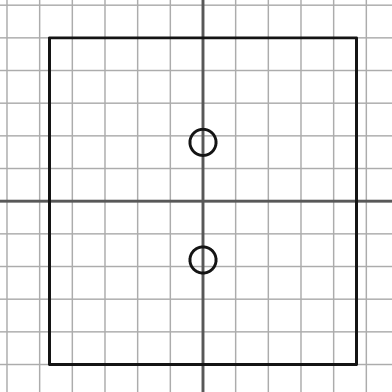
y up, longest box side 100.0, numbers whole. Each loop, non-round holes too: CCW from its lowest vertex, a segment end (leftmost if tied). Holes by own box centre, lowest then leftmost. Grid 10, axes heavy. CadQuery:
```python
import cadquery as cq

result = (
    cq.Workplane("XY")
    .moveTo(-47.0, -50.0)
    .lineTo(47.0, -50.0)
    .lineTo(47.0, 50.0)
    .lineTo(-47.0, 50.0)
    .close()
    .moveTo(0.0, -18.0)
    .circle(4.0)
    .moveTo(0.0, 18.0)
    .circle(4.0)
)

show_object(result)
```